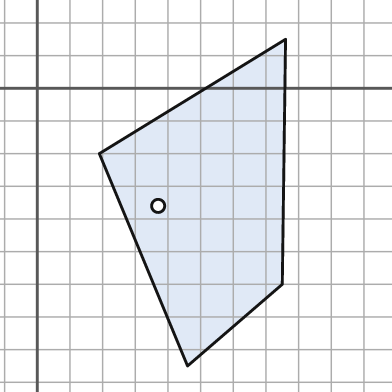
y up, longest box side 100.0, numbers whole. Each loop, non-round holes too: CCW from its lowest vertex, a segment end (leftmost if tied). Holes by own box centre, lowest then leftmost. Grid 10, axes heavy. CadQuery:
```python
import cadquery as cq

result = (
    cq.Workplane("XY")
    .moveTo(46.0, -85.0)
    .lineTo(75.0, -60.0)
    .lineTo(76.0, 15.0)
    .lineTo(19.0, -20.0)
    .close()
    .moveTo(37.0, -36.0)
    .circle(2.0)
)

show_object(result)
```